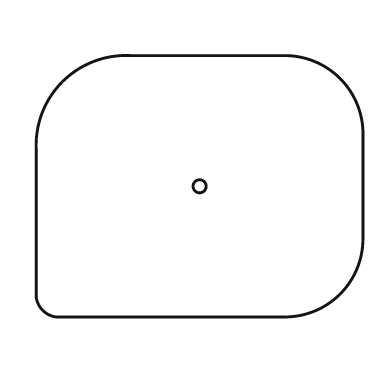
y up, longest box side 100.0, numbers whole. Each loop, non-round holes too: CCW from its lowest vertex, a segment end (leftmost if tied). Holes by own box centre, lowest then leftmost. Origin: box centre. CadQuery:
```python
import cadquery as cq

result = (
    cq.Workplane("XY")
    .moveTo(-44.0, -40.0)
    .lineTo(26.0, -40.0)
    .threePointArc((43.0, -33.0), (50.0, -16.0))
    .lineTo(50.0, 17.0)
    .threePointArc((43.0, 33.0), (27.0, 40.0))
    .lineTo(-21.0, 40.0)
    .threePointArc((-42.0, 32.0), (-50.0, 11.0))
    .lineTo(-50.0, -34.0)
    .threePointArc((-48.0, -38.0), (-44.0, -40.0))
    .close()
    .moveTo(0.0, 0.0)
    .circle(2.0)
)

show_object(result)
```